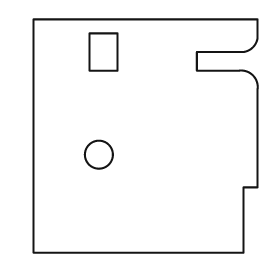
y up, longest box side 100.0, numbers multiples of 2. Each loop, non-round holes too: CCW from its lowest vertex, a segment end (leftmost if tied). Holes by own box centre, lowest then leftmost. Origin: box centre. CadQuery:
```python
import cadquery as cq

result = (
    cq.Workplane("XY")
    .moveTo(-48.0, -50.0)
    .lineTo(42.0, -50.0)
    .lineTo(42.0, -22.0)
    .lineTo(48.0, -22.0)
    .lineTo(48.0, 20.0)
    .threePointArc((46.0, 26.0), (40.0, 28.0))
    .lineTo(22.0, 28.0)
    .lineTo(22.0, 36.0)
    .lineTo(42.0, 36.0)
    .threePointArc((46.0, 38.0), (48.0, 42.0))
    .lineTo(48.0, 50.0)
    .lineTo(-48.0, 50.0)
    .close()
    .moveTo(-20.0, -8.0)
    .circle(6.0)
    .moveTo(-24.0, 28.0)
    .lineTo(-12.0, 28.0)
    .lineTo(-12.0, 44.0)
    .lineTo(-24.0, 44.0)
    .close()
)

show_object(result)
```